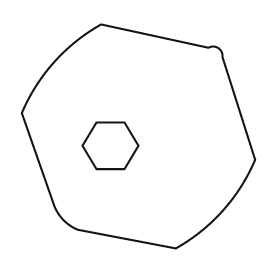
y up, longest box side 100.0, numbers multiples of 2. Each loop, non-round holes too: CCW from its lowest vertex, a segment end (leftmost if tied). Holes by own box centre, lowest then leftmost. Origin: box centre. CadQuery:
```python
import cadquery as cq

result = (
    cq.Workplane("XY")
    .moveTo(16.0, -48.0)
    .threePointArc((36.0, -32.0), (50.0, -10.0))
    .lineTo(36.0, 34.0)
    .threePointArc((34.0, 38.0), (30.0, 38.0))
    .lineTo(-16.0, 48.0)
    .threePointArc((-36.0, 32.0), (-50.0, 10.0))
    .lineTo(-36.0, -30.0)
    .threePointArc((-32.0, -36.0), (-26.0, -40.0))
    .close()
    .moveTo(-18.0, -14.0)
    .lineTo(-6.0, -14.0)
    .lineTo(0.0, -4.0)
    .lineTo(-6.0, 6.0)
    .lineTo(-18.0, 6.0)
    .lineTo(-24.0, -4.0)
    .close()
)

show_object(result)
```